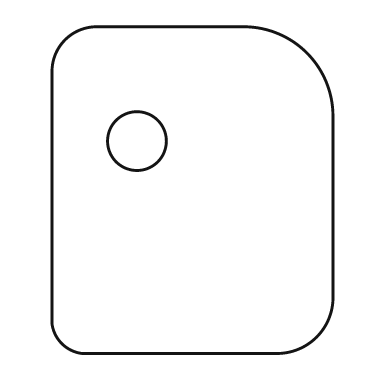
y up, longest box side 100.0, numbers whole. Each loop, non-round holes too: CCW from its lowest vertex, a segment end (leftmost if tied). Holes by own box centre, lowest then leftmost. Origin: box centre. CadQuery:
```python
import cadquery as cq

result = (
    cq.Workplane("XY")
    .moveTo(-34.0, -50.0)
    .lineTo(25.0, -50.0)
    .threePointArc((38.0, -45.0), (43.0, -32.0))
    .lineTo(43.0, 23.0)
    .threePointArc((35.0, 42.0), (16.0, 50.0))
    .lineTo(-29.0, 50.0)
    .threePointArc((-39.0, 46.0), (-43.0, 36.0))
    .lineTo(-43.0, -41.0)
    .threePointArc((-40.0, -47.0), (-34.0, -50.0))
    .close()
    .moveTo(-17.0, 15.0)
    .circle(9.0)
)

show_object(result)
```